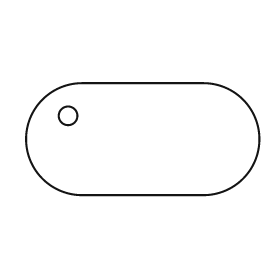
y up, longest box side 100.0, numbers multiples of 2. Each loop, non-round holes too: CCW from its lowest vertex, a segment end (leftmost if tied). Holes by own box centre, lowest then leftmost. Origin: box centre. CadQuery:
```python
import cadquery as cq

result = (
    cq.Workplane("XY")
    .moveTo(-26.0, -24.0)
    .lineTo(26.0, -24.0)
    .threePointArc((50.0, 0.0), (26.0, 24.0))
    .lineTo(-26.0, 24.0)
    .threePointArc((-50.0, 0.0), (-26.0, -24.0))
    .close()
    .moveTo(-32.0, 10.0)
    .circle(4.0)
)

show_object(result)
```